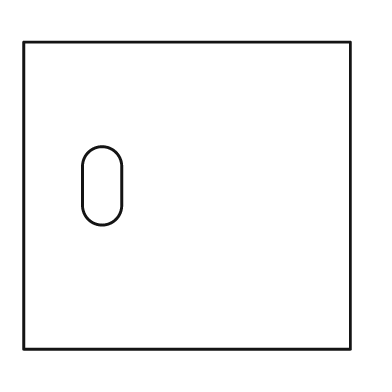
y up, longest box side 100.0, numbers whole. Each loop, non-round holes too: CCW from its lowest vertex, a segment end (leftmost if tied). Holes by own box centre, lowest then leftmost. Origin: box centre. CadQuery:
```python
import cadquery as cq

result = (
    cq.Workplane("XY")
    .moveTo(-50.0, -47.0)
    .lineTo(50.0, -47.0)
    .lineTo(50.0, 47.0)
    .lineTo(-50.0, 47.0)
    .close()
    .moveTo(-32.0, -3.0)
    .threePointArc((-26.0, -9.0), (-20.0, -3.0))
    .lineTo(-20.0, 9.0)
    .threePointArc((-26.0, 15.0), (-32.0, 9.0))
    .close()
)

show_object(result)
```